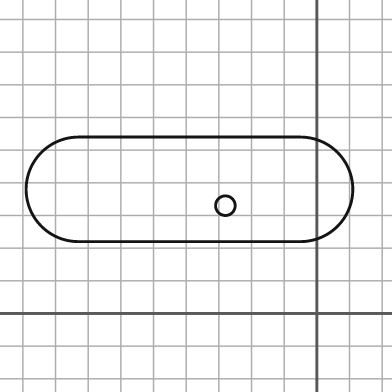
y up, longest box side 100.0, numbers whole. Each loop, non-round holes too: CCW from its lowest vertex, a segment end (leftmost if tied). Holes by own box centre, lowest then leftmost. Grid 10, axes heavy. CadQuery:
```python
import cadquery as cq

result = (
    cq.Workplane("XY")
    .moveTo(-73.0, 22.0)
    .lineTo(-5.0, 22.0)
    .threePointArc((11.0, 38.0), (-5.0, 54.0))
    .lineTo(-73.0, 54.0)
    .threePointArc((-89.0, 38.0), (-73.0, 22.0))
    .close()
    .moveTo(-28.0, 33.0)
    .circle(3.0)
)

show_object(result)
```